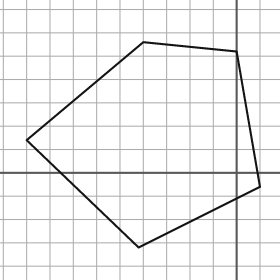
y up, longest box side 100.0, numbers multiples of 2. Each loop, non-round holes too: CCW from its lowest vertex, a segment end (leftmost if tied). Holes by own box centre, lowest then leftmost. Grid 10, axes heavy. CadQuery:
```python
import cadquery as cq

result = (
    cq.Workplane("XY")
    .moveTo(-42.0, -32.0)
    .lineTo(10.0, -6.0)
    .lineTo(0.0, 52.0)
    .lineTo(-40.0, 56.0)
    .lineTo(-90.0, 14.0)
    .close()
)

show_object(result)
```